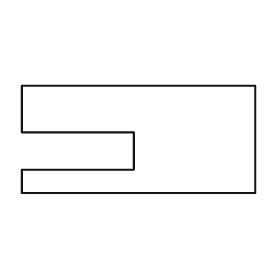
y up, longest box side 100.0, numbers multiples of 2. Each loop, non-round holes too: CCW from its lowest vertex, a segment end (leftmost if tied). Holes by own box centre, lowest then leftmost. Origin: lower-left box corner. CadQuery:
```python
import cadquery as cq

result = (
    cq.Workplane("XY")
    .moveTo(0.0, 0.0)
    .lineTo(100.0, 0.0)
    .lineTo(100.0, 46.0)
    .lineTo(0.0, 46.0)
    .lineTo(0.0, 26.0)
    .lineTo(48.0, 26.0)
    .lineTo(48.0, 10.0)
    .lineTo(0.0, 10.0)
    .close()
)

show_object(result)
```